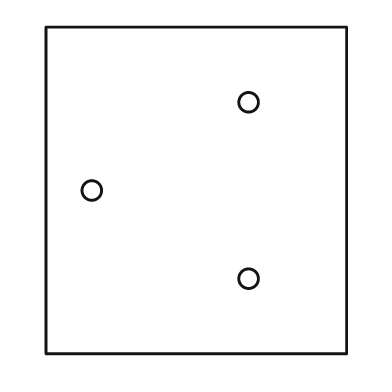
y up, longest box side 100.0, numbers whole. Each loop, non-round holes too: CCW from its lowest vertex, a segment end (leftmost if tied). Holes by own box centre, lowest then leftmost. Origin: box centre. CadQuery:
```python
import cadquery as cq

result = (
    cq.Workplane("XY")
    .moveTo(-46.0, -50.0)
    .lineTo(46.0, -50.0)
    .lineTo(46.0, 50.0)
    .lineTo(-46.0, 50.0)
    .close()
    .moveTo(16.0, -27.0)
    .circle(3.0)
    .moveTo(-32.0, 0.0)
    .circle(3.0)
    .moveTo(16.0, 27.0)
    .circle(3.0)
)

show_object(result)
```